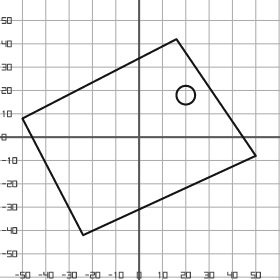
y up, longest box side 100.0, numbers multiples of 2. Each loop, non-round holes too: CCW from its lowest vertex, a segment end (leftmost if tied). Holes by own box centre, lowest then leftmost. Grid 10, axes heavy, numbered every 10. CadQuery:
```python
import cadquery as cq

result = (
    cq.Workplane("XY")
    .moveTo(-24.0, -42.0)
    .lineTo(50.0, -8.0)
    .lineTo(16.0, 42.0)
    .lineTo(-50.0, 8.0)
    .close()
    .moveTo(20.0, 18.0)
    .circle(4.0)
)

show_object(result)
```